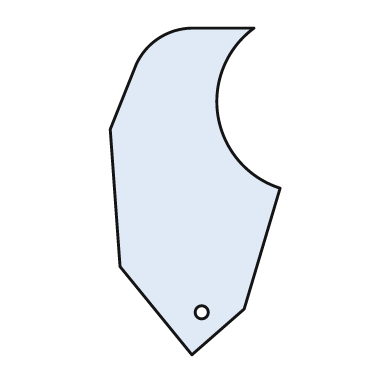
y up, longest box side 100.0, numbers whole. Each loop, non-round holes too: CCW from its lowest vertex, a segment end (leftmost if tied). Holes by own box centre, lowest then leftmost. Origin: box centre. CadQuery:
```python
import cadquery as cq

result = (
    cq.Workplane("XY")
    .moveTo(-1.0, -50.0)
    .lineTo(15.0, -36.0)
    .lineTo(26.0, 1.0)
    .threePointArc((7.0, 23.0), (18.0, 50.0))
    .lineTo(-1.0, 50.0)
    .threePointArc((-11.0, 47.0), (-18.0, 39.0))
    .lineTo(-26.0, 19.0)
    .lineTo(-23.0, -23.0)
    .close()
    .moveTo(2.0, -37.0)
    .circle(2.0)
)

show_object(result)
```